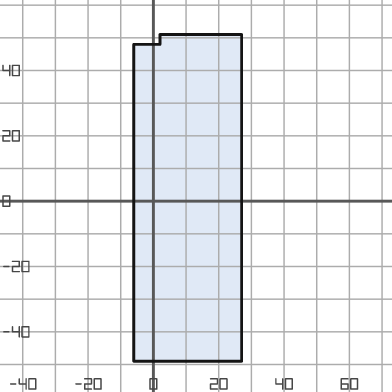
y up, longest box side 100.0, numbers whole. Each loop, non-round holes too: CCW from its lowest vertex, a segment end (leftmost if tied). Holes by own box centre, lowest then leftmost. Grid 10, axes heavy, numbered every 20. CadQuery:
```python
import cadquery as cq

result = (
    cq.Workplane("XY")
    .moveTo(-6.0, -49.0)
    .lineTo(27.0, -49.0)
    .lineTo(27.0, 51.0)
    .lineTo(2.0, 51.0)
    .lineTo(2.0, 48.0)
    .lineTo(-6.0, 48.0)
    .close()
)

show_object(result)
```